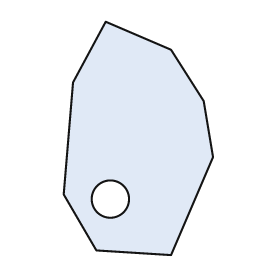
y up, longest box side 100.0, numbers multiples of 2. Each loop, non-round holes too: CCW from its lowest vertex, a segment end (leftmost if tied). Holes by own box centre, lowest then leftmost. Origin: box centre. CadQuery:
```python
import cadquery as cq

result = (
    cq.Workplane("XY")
    .moveTo(14.0, -50.0)
    .lineTo(32.0, -8.0)
    .lineTo(28.0, 16.0)
    .lineTo(14.0, 38.0)
    .lineTo(-14.0, 50.0)
    .lineTo(-28.0, 24.0)
    .lineTo(-32.0, -24.0)
    .lineTo(-18.0, -48.0)
    .close()
    .moveTo(-12.0, -26.0)
    .circle(8.0)
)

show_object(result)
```